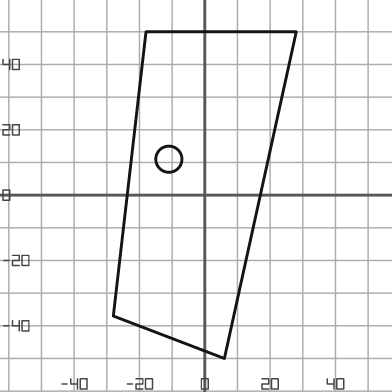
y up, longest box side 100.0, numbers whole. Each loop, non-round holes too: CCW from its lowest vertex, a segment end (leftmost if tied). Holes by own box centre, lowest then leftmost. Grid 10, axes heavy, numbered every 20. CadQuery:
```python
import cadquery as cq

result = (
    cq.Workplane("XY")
    .moveTo(6.0, -50.0)
    .lineTo(28.0, 50.0)
    .lineTo(-18.0, 50.0)
    .lineTo(-28.0, -37.0)
    .close()
    .moveTo(-11.0, 11.0)
    .circle(4.0)
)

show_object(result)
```